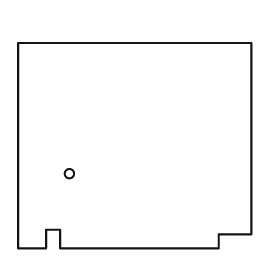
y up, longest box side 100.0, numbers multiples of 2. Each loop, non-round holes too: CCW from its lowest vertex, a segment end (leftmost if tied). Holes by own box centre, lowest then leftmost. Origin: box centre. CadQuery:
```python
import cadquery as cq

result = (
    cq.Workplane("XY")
    .moveTo(-50.0, -44.0)
    .lineTo(-38.0, -44.0)
    .lineTo(-38.0, -36.0)
    .lineTo(-32.0, -36.0)
    .lineTo(-32.0, -44.0)
    .lineTo(36.0, -44.0)
    .lineTo(36.0, -38.0)
    .lineTo(50.0, -38.0)
    .lineTo(50.0, 44.0)
    .lineTo(-50.0, 44.0)
    .close()
    .moveTo(-28.0, -12.0)
    .circle(2.0)
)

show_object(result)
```